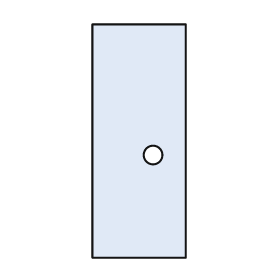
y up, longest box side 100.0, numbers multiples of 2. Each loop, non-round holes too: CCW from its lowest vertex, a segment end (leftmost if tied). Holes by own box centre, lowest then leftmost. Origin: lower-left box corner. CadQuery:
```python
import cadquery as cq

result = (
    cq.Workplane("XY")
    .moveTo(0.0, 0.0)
    .lineTo(40.0, 0.0)
    .lineTo(40.0, 100.0)
    .lineTo(0.0, 100.0)
    .close()
    .moveTo(26.0, 44.0)
    .circle(4.0)
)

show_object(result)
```